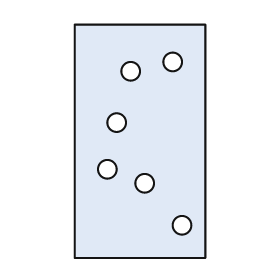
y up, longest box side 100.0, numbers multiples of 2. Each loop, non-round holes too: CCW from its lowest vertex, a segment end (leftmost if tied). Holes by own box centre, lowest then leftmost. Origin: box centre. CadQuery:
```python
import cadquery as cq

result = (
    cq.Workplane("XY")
    .moveTo(-28.0, -50.0)
    .lineTo(28.0, -50.0)
    .lineTo(28.0, 50.0)
    .lineTo(-28.0, 50.0)
    .close()
    .moveTo(18.0, -36.0)
    .circle(4.0)
    .moveTo(2.0, -18.0)
    .circle(4.0)
    .moveTo(-14.0, -12.0)
    .circle(4.0)
    .moveTo(-10.0, 8.0)
    .circle(4.0)
    .moveTo(-4.0, 30.0)
    .circle(4.0)
    .moveTo(14.0, 34.0)
    .circle(4.0)
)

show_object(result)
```